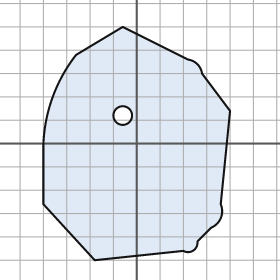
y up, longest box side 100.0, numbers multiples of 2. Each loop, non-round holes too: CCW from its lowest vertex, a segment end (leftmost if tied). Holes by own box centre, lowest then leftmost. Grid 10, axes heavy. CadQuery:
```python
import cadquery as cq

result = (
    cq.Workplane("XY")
    .moveTo(-18.0, -50.0)
    .lineTo(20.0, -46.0)
    .threePointArc((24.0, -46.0), (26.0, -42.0))
    .lineTo(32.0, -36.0)
    .threePointArc((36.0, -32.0), (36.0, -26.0))
    .lineTo(40.0, 14.0)
    .lineTo(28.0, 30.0)
    .threePointArc((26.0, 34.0), (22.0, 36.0))
    .lineTo(-6.0, 50.0)
    .lineTo(-26.0, 38.0)
    .threePointArc((-36.0, 20.0), (-40.0, 0.0))
    .lineTo(-40.0, -26.0)
    .close()
    .moveTo(-6.0, 12.0)
    .circle(4.0)
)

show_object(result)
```